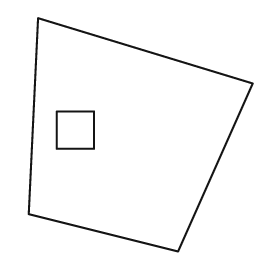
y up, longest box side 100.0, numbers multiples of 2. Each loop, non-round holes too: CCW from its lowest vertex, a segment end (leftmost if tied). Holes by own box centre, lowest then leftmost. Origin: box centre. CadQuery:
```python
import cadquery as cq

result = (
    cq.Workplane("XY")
    .moveTo(16.0, -50.0)
    .lineTo(48.0, 22.0)
    .lineTo(-44.0, 50.0)
    .lineTo(-48.0, -34.0)
    .close()
    .moveTo(-36.0, -6.0)
    .lineTo(-20.0, -6.0)
    .lineTo(-20.0, 10.0)
    .lineTo(-36.0, 10.0)
    .close()
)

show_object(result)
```